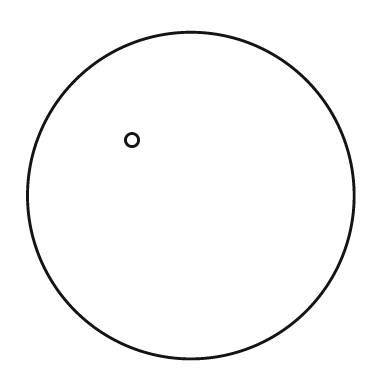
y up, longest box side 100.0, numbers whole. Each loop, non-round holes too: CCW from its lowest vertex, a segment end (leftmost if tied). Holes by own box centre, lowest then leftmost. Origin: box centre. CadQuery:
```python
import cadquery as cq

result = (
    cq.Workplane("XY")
    .moveTo(0.0, 0.0)
    .circle(50.0)
    .moveTo(-18.0, 17.0)
    .circle(2.0)
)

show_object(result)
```